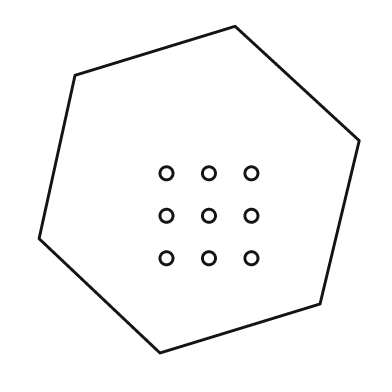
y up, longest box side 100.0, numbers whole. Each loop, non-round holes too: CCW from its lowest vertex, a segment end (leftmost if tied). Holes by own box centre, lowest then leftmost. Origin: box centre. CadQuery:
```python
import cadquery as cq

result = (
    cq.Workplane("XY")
    .moveTo(-12.0, -50.0)
    .lineTo(37.0, -35.0)
    .lineTo(49.0, 15.0)
    .lineTo(11.0, 50.0)
    .lineTo(-38.0, 35.0)
    .lineTo(-49.0, -15.0)
    .close()
    .moveTo(-10.0, -21.0)
    .circle(2.0)
    .moveTo(3.0, -21.0)
    .circle(2.0)
    .moveTo(16.0, -21.0)
    .circle(2.0)
    .moveTo(-10.0, -8.0)
    .circle(2.0)
    .moveTo(3.0, -8.0)
    .circle(2.0)
    .moveTo(16.0, -8.0)
    .circle(2.0)
    .moveTo(-10.0, 5.0)
    .circle(2.0)
    .moveTo(3.0, 5.0)
    .circle(2.0)
    .moveTo(16.0, 5.0)
    .circle(2.0)
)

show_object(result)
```